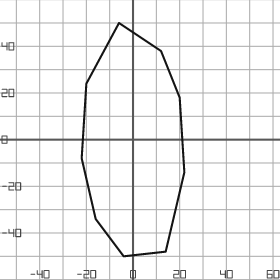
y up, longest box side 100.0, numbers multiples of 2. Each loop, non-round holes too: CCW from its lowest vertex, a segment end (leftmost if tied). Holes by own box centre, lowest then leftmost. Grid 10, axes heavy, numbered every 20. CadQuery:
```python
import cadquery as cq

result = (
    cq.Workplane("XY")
    .moveTo(-4.0, -50.0)
    .lineTo(14.0, -48.0)
    .lineTo(22.0, -14.0)
    .lineTo(20.0, 18.0)
    .lineTo(12.0, 38.0)
    .lineTo(-6.0, 50.0)
    .lineTo(-20.0, 24.0)
    .lineTo(-22.0, -8.0)
    .lineTo(-16.0, -34.0)
    .close()
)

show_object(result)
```